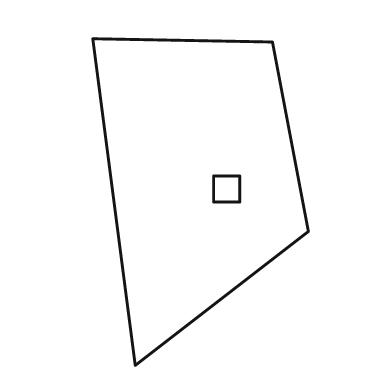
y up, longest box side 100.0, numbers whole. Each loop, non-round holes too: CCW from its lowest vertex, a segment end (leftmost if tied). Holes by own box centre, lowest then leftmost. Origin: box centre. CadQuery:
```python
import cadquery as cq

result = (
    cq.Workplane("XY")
    .moveTo(-20.0, -50.0)
    .lineTo(33.0, -9.0)
    .lineTo(22.0, 49.0)
    .lineTo(-33.0, 50.0)
    .close()
    .moveTo(4.0, 0.0)
    .lineTo(12.0, 0.0)
    .lineTo(12.0, 8.0)
    .lineTo(4.0, 8.0)
    .close()
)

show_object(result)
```